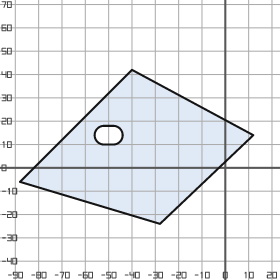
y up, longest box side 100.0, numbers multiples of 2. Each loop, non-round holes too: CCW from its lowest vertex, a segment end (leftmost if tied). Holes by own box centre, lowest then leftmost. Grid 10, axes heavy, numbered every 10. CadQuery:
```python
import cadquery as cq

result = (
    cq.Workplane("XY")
    .moveTo(-28.0, -24.0)
    .lineTo(12.0, 14.0)
    .lineTo(-40.0, 42.0)
    .lineTo(-88.0, -6.0)
    .close()
    .moveTo(-52.0, 10.0)
    .lineTo(-48.0, 10.0)
    .threePointArc((-44.0, 14.0), (-48.0, 18.0))
    .lineTo(-52.0, 18.0)
    .threePointArc((-56.0, 14.0), (-52.0, 10.0))
    .close()
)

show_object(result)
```